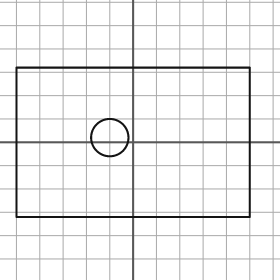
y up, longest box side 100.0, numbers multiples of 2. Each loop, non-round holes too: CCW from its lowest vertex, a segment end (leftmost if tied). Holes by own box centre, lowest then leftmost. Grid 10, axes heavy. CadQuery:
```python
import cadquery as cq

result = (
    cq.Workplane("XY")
    .moveTo(-50.0, -32.0)
    .lineTo(50.0, -32.0)
    .lineTo(50.0, 32.0)
    .lineTo(-50.0, 32.0)
    .close()
    .moveTo(-10.0, 2.0)
    .circle(8.0)
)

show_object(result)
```